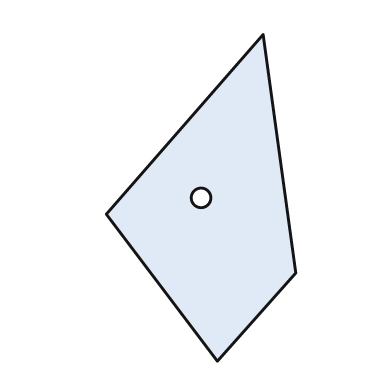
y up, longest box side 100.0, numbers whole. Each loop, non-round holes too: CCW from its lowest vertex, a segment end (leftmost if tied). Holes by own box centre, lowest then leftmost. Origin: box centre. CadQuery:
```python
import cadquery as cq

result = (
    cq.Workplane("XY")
    .moveTo(5.0, -50.0)
    .lineTo(29.0, -23.0)
    .lineTo(19.0, 50.0)
    .lineTo(-29.0, -5.0)
    .close()
    .moveTo(0.0, 0.0)
    .circle(3.0)
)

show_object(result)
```